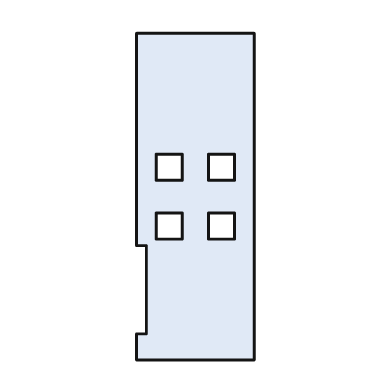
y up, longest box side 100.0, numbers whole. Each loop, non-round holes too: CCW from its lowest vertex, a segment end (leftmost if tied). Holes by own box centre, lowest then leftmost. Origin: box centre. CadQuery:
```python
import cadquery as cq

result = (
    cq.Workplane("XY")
    .moveTo(-18.0, -50.0)
    .lineTo(18.0, -50.0)
    .lineTo(18.0, 50.0)
    .lineTo(-18.0, 50.0)
    .lineTo(-18.0, -15.0)
    .lineTo(-15.0, -15.0)
    .lineTo(-15.0, -42.0)
    .lineTo(-18.0, -42.0)
    .close()
    .moveTo(-12.0, -13.0)
    .lineTo(-4.0, -13.0)
    .lineTo(-4.0, -5.0)
    .lineTo(-12.0, -5.0)
    .close()
    .moveTo(4.0, -13.0)
    .lineTo(12.0, -13.0)
    .lineTo(12.0, -5.0)
    .lineTo(4.0, -5.0)
    .close()
    .moveTo(-12.0, 5.0)
    .lineTo(-4.0, 5.0)
    .lineTo(-4.0, 13.0)
    .lineTo(-12.0, 13.0)
    .close()
    .moveTo(4.0, 5.0)
    .lineTo(12.0, 5.0)
    .lineTo(12.0, 13.0)
    .lineTo(4.0, 13.0)
    .close()
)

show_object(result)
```